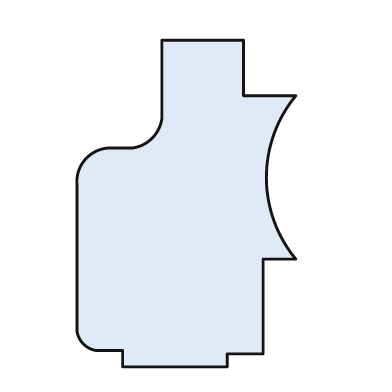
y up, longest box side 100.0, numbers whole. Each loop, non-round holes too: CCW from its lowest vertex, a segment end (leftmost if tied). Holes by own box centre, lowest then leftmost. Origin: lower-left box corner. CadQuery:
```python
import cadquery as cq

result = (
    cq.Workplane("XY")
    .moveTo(14.0, 0.0)
    .lineTo(46.0, 0.0)
    .lineTo(46.0, 4.0)
    .lineTo(57.0, 4.0)
    .lineTo(57.0, 33.0)
    .lineTo(67.0, 33.0)
    .threePointArc((58.0, 58.0), (67.0, 83.0))
    .lineTo(51.0, 83.0)
    .lineTo(51.0, 100.0)
    .lineTo(26.0, 100.0)
    .lineTo(26.0, 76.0)
    .threePointArc((23.0, 70.0), (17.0, 67.0))
    .lineTo(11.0, 67.0)
    .threePointArc((3.0, 64.0), (0.0, 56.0))
    .lineTo(0.0, 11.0)
    .threePointArc((2.0, 7.0), (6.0, 5.0))
    .lineTo(14.0, 5.0)
    .close()
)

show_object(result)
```